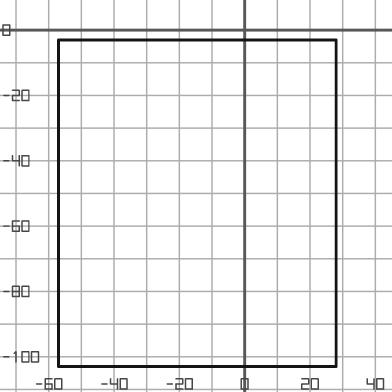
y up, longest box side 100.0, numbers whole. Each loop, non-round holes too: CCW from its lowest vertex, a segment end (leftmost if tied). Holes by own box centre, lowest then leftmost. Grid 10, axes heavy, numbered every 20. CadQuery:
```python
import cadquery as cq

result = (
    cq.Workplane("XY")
    .moveTo(-57.0, -103.0)
    .lineTo(28.0, -103.0)
    .lineTo(28.0, -3.0)
    .lineTo(-57.0, -3.0)
    .close()
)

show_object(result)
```